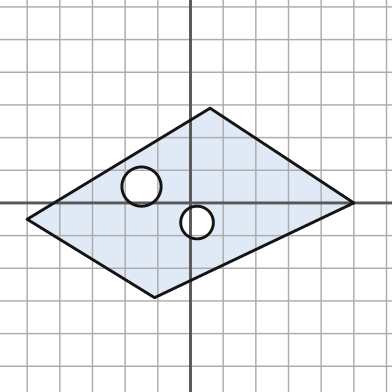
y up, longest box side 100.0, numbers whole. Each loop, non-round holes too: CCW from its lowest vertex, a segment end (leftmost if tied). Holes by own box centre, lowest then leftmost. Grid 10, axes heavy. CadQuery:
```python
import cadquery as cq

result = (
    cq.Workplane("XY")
    .moveTo(-11.0, -29.0)
    .lineTo(50.0, 0.0)
    .lineTo(6.0, 29.0)
    .lineTo(-50.0, -5.0)
    .close()
    .moveTo(2.0, -6.0)
    .circle(5.0)
    .moveTo(-15.0, 5.0)
    .circle(6.0)
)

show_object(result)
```